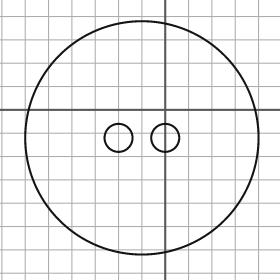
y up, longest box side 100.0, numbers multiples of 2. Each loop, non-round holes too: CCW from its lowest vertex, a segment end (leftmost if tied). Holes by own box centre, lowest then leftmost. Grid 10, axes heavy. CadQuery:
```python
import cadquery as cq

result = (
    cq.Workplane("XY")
    .moveTo(-10.0, -12.0)
    .circle(50.0)
    .moveTo(-20.0, -12.0)
    .circle(6.0)
    .moveTo(0.0, -12.0)
    .circle(6.0)
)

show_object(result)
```